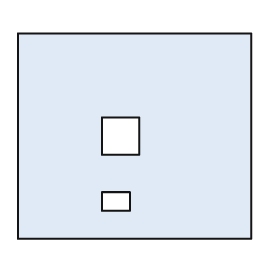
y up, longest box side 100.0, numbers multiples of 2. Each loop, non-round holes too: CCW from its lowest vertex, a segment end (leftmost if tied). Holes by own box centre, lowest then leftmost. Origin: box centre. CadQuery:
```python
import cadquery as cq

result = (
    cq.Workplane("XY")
    .moveTo(-50.0, -44.0)
    .lineTo(50.0, -44.0)
    .lineTo(50.0, 44.0)
    .lineTo(-50.0, 44.0)
    .close()
    .moveTo(-14.0, -32.0)
    .lineTo(-2.0, -32.0)
    .lineTo(-2.0, -24.0)
    .lineTo(-14.0, -24.0)
    .close()
    .moveTo(-14.0, -8.0)
    .lineTo(2.0, -8.0)
    .lineTo(2.0, 8.0)
    .lineTo(-14.0, 8.0)
    .close()
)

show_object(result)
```